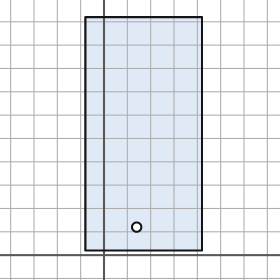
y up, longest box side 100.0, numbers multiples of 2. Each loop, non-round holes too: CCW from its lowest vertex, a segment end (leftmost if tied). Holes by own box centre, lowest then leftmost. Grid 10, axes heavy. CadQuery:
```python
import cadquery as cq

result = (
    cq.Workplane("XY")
    .moveTo(-8.0, 2.0)
    .lineTo(42.0, 2.0)
    .lineTo(42.0, 102.0)
    .lineTo(-8.0, 102.0)
    .close()
    .moveTo(14.0, 12.0)
    .circle(2.0)
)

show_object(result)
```